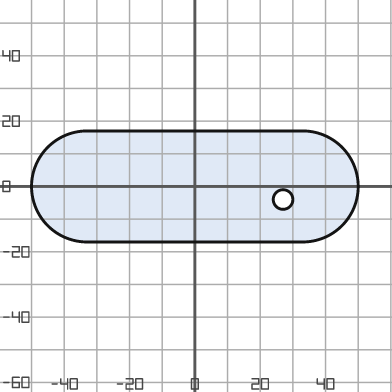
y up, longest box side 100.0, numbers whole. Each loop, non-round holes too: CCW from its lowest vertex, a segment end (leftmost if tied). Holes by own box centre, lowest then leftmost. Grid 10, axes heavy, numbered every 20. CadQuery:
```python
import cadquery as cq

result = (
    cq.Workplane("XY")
    .moveTo(-33.0, -17.0)
    .lineTo(33.0, -17.0)
    .threePointArc((50.0, 0.0), (33.0, 17.0))
    .lineTo(-33.0, 17.0)
    .threePointArc((-50.0, 0.0), (-33.0, -17.0))
    .close()
    .moveTo(27.0, -4.0)
    .circle(3.0)
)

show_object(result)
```